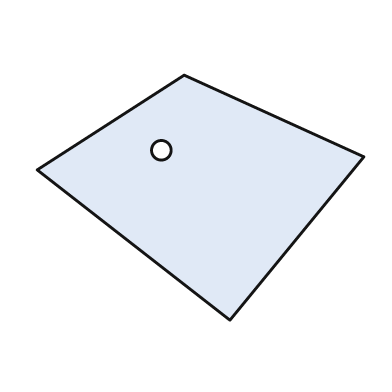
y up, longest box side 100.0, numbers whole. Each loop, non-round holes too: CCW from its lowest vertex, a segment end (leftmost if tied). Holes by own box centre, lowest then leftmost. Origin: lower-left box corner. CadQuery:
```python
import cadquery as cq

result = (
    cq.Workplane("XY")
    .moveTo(59.0, 0.0)
    .lineTo(100.0, 50.0)
    .lineTo(45.0, 75.0)
    .lineTo(0.0, 46.0)
    .close()
    .moveTo(38.0, 52.0)
    .circle(3.0)
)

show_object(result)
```